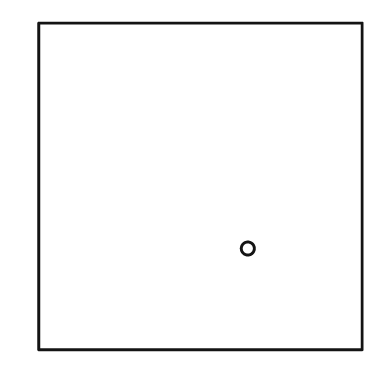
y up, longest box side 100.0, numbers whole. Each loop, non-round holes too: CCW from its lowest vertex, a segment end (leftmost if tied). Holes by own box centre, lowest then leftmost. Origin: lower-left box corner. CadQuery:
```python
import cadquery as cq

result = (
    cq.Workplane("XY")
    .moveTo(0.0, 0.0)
    .lineTo(99.0, 0.0)
    .lineTo(99.0, 100.0)
    .lineTo(0.0, 100.0)
    .close()
    .moveTo(64.0, 31.0)
    .circle(2.0)
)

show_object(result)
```